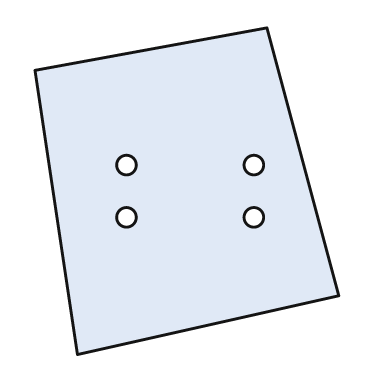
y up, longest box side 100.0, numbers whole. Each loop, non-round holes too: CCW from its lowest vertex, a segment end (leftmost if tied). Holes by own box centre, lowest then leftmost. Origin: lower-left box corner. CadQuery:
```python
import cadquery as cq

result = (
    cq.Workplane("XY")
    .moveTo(13.0, 0.0)
    .lineTo(93.0, 18.0)
    .lineTo(71.0, 100.0)
    .lineTo(0.0, 87.0)
    .close()
    .moveTo(28.0, 42.0)
    .circle(3.0)
    .moveTo(67.0, 42.0)
    .circle(3.0)
    .moveTo(28.0, 58.0)
    .circle(3.0)
    .moveTo(67.0, 58.0)
    .circle(3.0)
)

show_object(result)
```